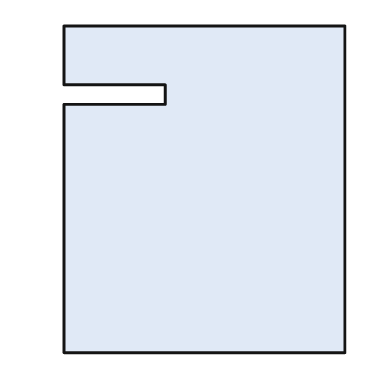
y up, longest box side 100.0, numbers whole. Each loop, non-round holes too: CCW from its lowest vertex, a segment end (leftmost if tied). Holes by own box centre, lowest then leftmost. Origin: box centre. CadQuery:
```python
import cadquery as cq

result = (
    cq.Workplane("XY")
    .moveTo(-43.0, -50.0)
    .lineTo(43.0, -50.0)
    .lineTo(43.0, 50.0)
    .lineTo(-43.0, 50.0)
    .lineTo(-43.0, 32.0)
    .lineTo(-12.0, 32.0)
    .lineTo(-12.0, 26.0)
    .lineTo(-43.0, 26.0)
    .close()
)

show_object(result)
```